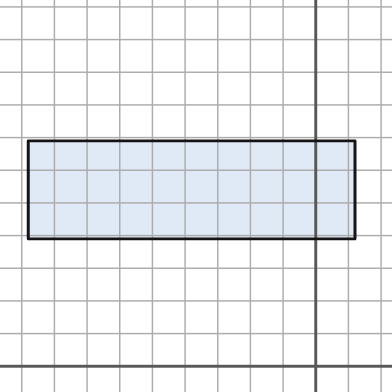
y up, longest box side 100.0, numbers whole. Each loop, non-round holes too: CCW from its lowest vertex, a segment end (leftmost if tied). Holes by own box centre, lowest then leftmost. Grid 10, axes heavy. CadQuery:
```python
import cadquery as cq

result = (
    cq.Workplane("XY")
    .moveTo(-88.0, 39.0)
    .lineTo(12.0, 39.0)
    .lineTo(12.0, 69.0)
    .lineTo(-88.0, 69.0)
    .close()
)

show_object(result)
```